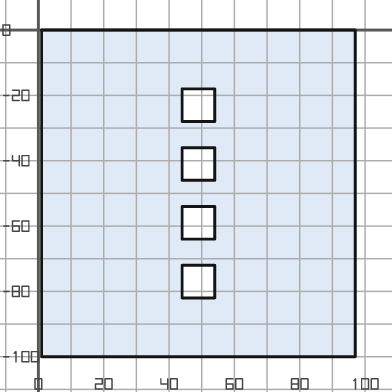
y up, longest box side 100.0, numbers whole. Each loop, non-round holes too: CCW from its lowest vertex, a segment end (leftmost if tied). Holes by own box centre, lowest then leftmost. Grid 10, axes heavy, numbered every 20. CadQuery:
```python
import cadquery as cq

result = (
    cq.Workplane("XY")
    .moveTo(1.0, -100.0)
    .lineTo(97.0, -100.0)
    .lineTo(97.0, 0.0)
    .lineTo(1.0, 0.0)
    .close()
    .moveTo(44.0, -82.0)
    .lineTo(54.0, -82.0)
    .lineTo(54.0, -72.0)
    .lineTo(44.0, -72.0)
    .close()
    .moveTo(44.0, -64.0)
    .lineTo(54.0, -64.0)
    .lineTo(54.0, -54.0)
    .lineTo(44.0, -54.0)
    .close()
    .moveTo(44.0, -46.0)
    .lineTo(54.0, -46.0)
    .lineTo(54.0, -36.0)
    .lineTo(44.0, -36.0)
    .close()
    .moveTo(44.0, -28.0)
    .lineTo(54.0, -28.0)
    .lineTo(54.0, -18.0)
    .lineTo(44.0, -18.0)
    .close()
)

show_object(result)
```